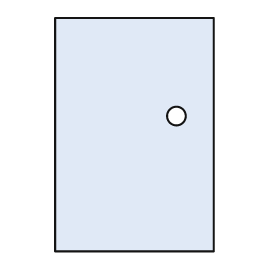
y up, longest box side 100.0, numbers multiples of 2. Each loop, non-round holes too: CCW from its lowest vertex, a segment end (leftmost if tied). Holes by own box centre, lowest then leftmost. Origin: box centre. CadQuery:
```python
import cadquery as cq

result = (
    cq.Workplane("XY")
    .moveTo(-34.0, -50.0)
    .lineTo(34.0, -50.0)
    .lineTo(34.0, 50.0)
    .lineTo(-34.0, 50.0)
    .close()
    .moveTo(18.0, 8.0)
    .circle(4.0)
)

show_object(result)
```